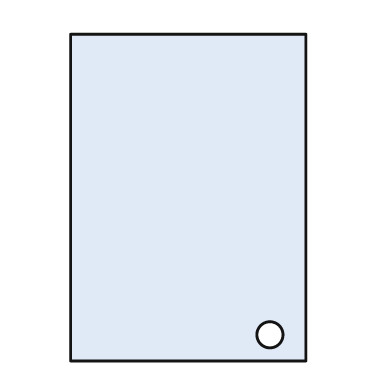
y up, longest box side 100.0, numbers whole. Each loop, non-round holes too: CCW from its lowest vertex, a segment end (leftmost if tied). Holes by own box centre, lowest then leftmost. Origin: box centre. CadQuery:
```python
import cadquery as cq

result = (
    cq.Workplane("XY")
    .moveTo(-36.0, -50.0)
    .lineTo(36.0, -50.0)
    .lineTo(36.0, 50.0)
    .lineTo(-36.0, 50.0)
    .close()
    .moveTo(25.0, -42.0)
    .circle(4.0)
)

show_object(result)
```